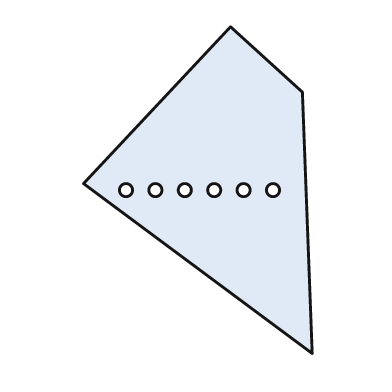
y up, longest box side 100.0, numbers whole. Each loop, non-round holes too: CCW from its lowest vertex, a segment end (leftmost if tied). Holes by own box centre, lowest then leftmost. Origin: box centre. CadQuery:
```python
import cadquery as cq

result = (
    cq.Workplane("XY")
    .moveTo(35.0, -50.0)
    .lineTo(32.0, 30.0)
    .lineTo(10.0, 50.0)
    .lineTo(-35.0, 2.0)
    .close()
    .moveTo(-22.0, 0.0)
    .circle(2.0)
    .moveTo(-13.0, 0.0)
    .circle(2.0)
    .moveTo(-4.0, 0.0)
    .circle(2.0)
    .moveTo(5.0, 0.0)
    .circle(2.0)
    .moveTo(14.0, 0.0)
    .circle(2.0)
    .moveTo(23.0, 0.0)
    .circle(2.0)
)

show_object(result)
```